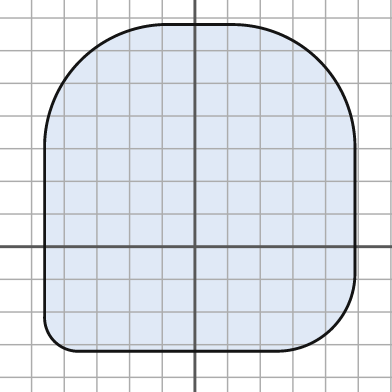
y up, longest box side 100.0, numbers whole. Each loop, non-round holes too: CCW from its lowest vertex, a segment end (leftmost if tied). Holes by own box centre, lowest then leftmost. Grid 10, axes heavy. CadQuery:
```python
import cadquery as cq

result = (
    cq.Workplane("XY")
    .moveTo(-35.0, -32.0)
    .lineTo(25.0, -32.0)
    .threePointArc((42.0, -25.0), (49.0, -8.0))
    .lineTo(49.0, 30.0)
    .threePointArc((38.0, 57.0), (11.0, 68.0))
    .lineTo(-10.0, 68.0)
    .threePointArc((-35.0, 57.0), (-46.0, 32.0))
    .lineTo(-46.0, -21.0)
    .threePointArc((-43.0, -29.0), (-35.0, -32.0))
    .close()
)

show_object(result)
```